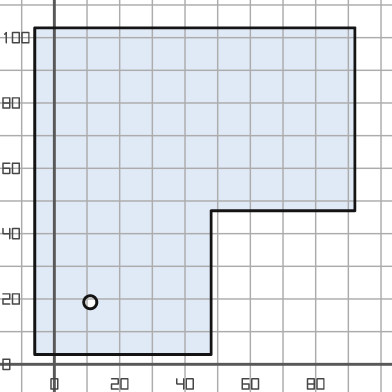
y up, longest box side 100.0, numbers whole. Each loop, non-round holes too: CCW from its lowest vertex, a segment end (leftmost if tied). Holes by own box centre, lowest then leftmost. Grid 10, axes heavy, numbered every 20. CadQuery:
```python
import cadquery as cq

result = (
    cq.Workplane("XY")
    .moveTo(-6.0, 3.0)
    .lineTo(48.0, 3.0)
    .lineTo(48.0, 47.0)
    .lineTo(92.0, 47.0)
    .lineTo(92.0, 103.0)
    .lineTo(-6.0, 103.0)
    .close()
    .moveTo(11.0, 19.0)
    .circle(2.0)
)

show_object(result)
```